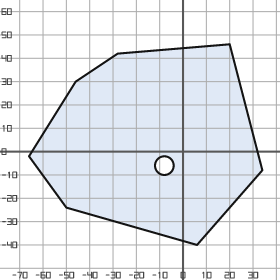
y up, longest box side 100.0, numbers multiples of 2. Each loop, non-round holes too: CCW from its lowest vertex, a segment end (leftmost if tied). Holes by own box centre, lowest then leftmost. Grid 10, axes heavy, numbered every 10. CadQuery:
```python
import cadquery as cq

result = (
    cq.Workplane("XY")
    .moveTo(6.0, -40.0)
    .lineTo(34.0, -8.0)
    .lineTo(20.0, 46.0)
    .lineTo(-28.0, 42.0)
    .lineTo(-46.0, 30.0)
    .lineTo(-66.0, -2.0)
    .lineTo(-50.0, -24.0)
    .close()
    .moveTo(-8.0, -6.0)
    .circle(4.0)
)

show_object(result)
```